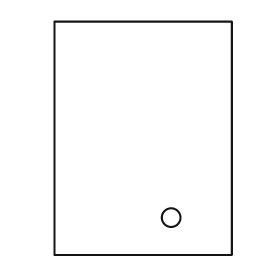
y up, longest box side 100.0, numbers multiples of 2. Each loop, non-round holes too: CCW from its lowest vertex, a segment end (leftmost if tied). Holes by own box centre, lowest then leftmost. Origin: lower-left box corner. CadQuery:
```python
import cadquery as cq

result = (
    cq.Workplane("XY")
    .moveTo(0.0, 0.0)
    .lineTo(76.0, 0.0)
    .lineTo(76.0, 100.0)
    .lineTo(0.0, 100.0)
    .close()
    .moveTo(50.0, 16.0)
    .circle(4.0)
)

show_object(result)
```